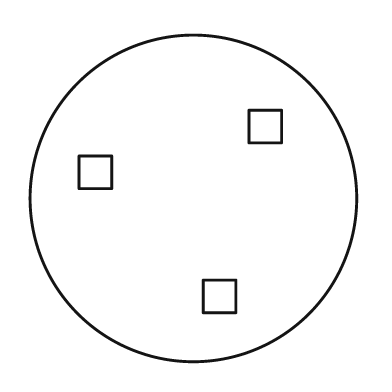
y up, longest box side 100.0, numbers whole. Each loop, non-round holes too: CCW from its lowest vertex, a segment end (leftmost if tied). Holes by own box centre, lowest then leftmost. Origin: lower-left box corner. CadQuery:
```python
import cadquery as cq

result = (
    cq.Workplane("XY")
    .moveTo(50.0, 50.0)
    .circle(50.0)
    .moveTo(53.0, 15.0)
    .lineTo(63.0, 15.0)
    .lineTo(63.0, 25.0)
    .lineTo(53.0, 25.0)
    .close()
    .moveTo(15.0, 53.0)
    .lineTo(25.0, 53.0)
    .lineTo(25.0, 63.0)
    .lineTo(15.0, 63.0)
    .close()
    .moveTo(67.0, 67.0)
    .lineTo(77.0, 67.0)
    .lineTo(77.0, 77.0)
    .lineTo(67.0, 77.0)
    .close()
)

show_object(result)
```